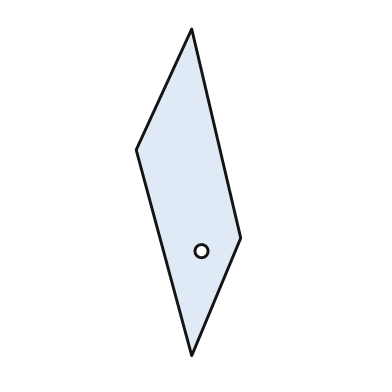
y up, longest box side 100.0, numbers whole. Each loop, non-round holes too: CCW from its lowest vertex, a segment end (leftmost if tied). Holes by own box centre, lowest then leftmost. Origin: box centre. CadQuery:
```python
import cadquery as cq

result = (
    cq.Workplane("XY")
    .moveTo(1.0, -50.0)
    .lineTo(16.0, -14.0)
    .lineTo(1.0, 50.0)
    .lineTo(-16.0, 13.0)
    .close()
    .moveTo(4.0, -18.0)
    .circle(2.0)
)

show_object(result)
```